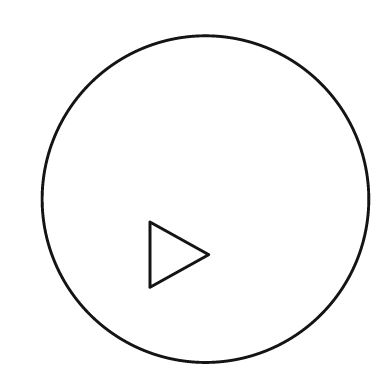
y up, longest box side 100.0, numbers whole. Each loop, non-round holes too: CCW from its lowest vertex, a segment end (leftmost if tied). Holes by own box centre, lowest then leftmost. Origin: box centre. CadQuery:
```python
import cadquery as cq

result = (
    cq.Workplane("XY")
    .moveTo(0.0, 0.0)
    .circle(50.0)
    .moveTo(-17.0, -27.0)
    .lineTo(1.0, -17.0)
    .lineTo(-17.0, -7.0)
    .close()
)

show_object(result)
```